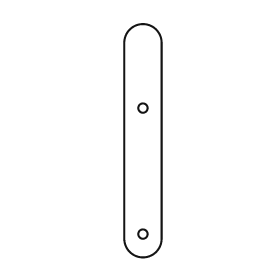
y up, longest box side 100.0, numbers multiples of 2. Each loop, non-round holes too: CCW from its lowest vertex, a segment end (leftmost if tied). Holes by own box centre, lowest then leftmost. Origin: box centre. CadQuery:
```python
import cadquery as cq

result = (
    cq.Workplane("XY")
    .moveTo(-8.0, -42.0)
    .threePointArc((0.0, -50.0), (8.0, -42.0))
    .lineTo(8.0, 42.0)
    .threePointArc((0.0, 50.0), (-8.0, 42.0))
    .close()
    .moveTo(0.0, -40.0)
    .circle(2.0)
    .moveTo(0.0, 14.0)
    .circle(2.0)
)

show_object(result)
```